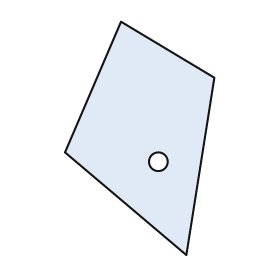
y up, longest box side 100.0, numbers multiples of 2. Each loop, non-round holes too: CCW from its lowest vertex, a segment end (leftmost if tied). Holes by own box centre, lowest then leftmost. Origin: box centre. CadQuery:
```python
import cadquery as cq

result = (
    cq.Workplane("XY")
    .moveTo(20.0, -50.0)
    .lineTo(32.0, 26.0)
    .lineTo(-8.0, 50.0)
    .lineTo(-32.0, -6.0)
    .close()
    .moveTo(8.0, -10.0)
    .circle(4.0)
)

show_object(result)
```